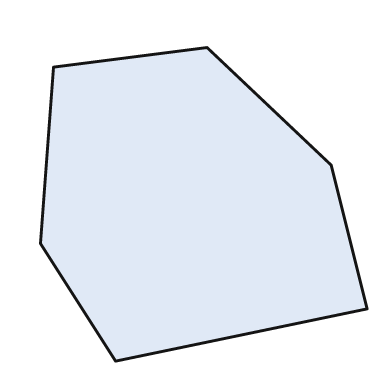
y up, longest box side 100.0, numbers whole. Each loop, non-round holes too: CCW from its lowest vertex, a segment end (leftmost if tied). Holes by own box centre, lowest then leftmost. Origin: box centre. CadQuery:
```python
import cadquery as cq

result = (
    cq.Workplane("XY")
    .moveTo(-27.0, -48.0)
    .lineTo(50.0, -32.0)
    .lineTo(39.0, 12.0)
    .lineTo(1.0, 48.0)
    .lineTo(-46.0, 42.0)
    .lineTo(-50.0, -12.0)
    .close()
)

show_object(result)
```